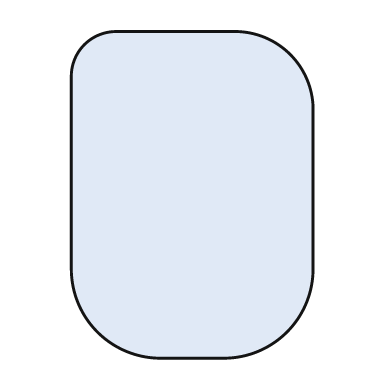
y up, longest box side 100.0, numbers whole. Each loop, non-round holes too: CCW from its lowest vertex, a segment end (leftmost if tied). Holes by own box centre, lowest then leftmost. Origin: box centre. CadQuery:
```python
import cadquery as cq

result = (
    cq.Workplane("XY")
    .moveTo(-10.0, -50.0)
    .lineTo(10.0, -50.0)
    .threePointArc((29.0, -42.0), (37.0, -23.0))
    .lineTo(37.0, 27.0)
    .threePointArc((30.0, 43.0), (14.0, 50.0))
    .lineTo(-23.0, 50.0)
    .threePointArc((-33.0, 46.0), (-37.0, 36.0))
    .lineTo(-37.0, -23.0)
    .threePointArc((-29.0, -42.0), (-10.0, -50.0))
    .close()
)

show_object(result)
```